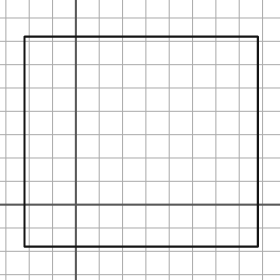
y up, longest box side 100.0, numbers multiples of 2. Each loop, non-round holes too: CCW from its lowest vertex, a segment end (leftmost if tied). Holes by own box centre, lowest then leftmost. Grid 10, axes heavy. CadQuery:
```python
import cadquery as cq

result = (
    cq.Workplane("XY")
    .moveTo(-22.0, -18.0)
    .lineTo(78.0, -18.0)
    .lineTo(78.0, 72.0)
    .lineTo(-22.0, 72.0)
    .close()
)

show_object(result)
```